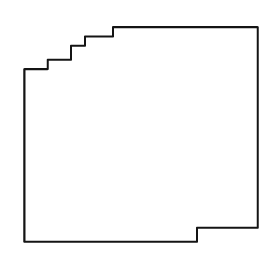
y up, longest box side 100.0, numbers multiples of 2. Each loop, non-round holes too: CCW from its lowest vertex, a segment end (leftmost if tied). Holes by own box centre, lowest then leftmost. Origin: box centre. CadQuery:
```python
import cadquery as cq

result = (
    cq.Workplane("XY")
    .moveTo(-50.0, -46.0)
    .lineTo(24.0, -46.0)
    .lineTo(24.0, -40.0)
    .lineTo(50.0, -40.0)
    .lineTo(50.0, 46.0)
    .lineTo(-12.0, 46.0)
    .lineTo(-12.0, 42.0)
    .lineTo(-24.0, 42.0)
    .lineTo(-24.0, 38.0)
    .lineTo(-30.0, 38.0)
    .lineTo(-30.0, 32.0)
    .lineTo(-40.0, 32.0)
    .lineTo(-40.0, 28.0)
    .lineTo(-50.0, 28.0)
    .close()
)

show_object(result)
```